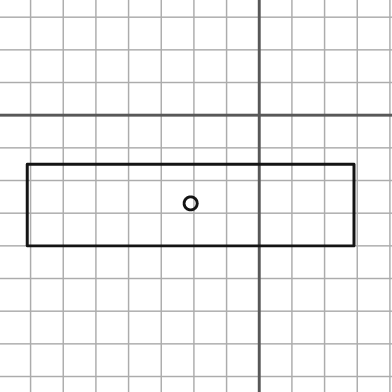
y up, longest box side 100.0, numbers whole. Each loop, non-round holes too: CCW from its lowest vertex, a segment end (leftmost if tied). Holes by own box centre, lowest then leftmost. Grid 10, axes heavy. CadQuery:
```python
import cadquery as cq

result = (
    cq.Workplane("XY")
    .moveTo(-71.0, -40.0)
    .lineTo(29.0, -40.0)
    .lineTo(29.0, -15.0)
    .lineTo(-71.0, -15.0)
    .close()
    .moveTo(-21.0, -27.0)
    .circle(2.0)
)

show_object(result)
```